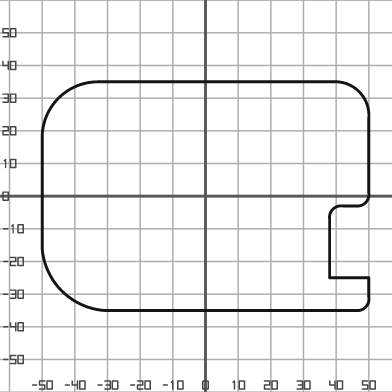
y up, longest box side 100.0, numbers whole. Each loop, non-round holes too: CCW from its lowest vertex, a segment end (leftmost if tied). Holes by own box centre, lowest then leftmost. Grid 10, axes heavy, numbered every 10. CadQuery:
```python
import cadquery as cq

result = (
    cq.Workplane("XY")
    .moveTo(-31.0, -35.0)
    .lineTo(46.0, -35.0)
    .threePointArc((49.0, -34.0), (50.0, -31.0))
    .lineTo(50.0, -25.0)
    .lineTo(38.0, -25.0)
    .lineTo(38.0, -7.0)
    .threePointArc((39.0, -4.0), (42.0, -3.0))
    .lineTo(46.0, -3.0)
    .threePointArc((49.0, -2.0), (50.0, 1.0))
    .lineTo(50.0, 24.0)
    .threePointArc((47.0, 32.0), (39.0, 35.0))
    .lineTo(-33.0, 35.0)
    .threePointArc((-45.0, 30.0), (-50.0, 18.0))
    .lineTo(-50.0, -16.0)
    .threePointArc((-44.0, -29.0), (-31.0, -35.0))
    .close()
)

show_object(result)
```